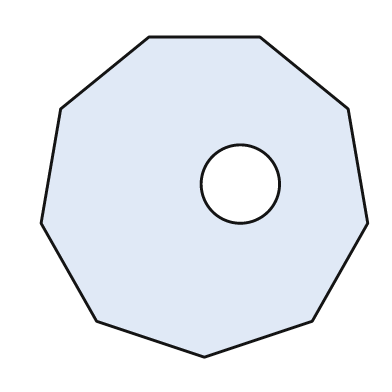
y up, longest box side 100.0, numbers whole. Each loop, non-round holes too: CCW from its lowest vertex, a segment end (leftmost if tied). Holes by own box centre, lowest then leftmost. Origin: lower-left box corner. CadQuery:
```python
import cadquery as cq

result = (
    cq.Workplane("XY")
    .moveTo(50.0, 0.0)
    .lineTo(83.0, 11.0)
    .lineTo(100.0, 41.0)
    .lineTo(94.0, 76.0)
    .lineTo(67.0, 98.0)
    .lineTo(33.0, 98.0)
    .lineTo(6.0, 76.0)
    .lineTo(0.0, 41.0)
    .lineTo(17.0, 11.0)
    .close()
    .moveTo(61.0, 53.0)
    .circle(12.0)
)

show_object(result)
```